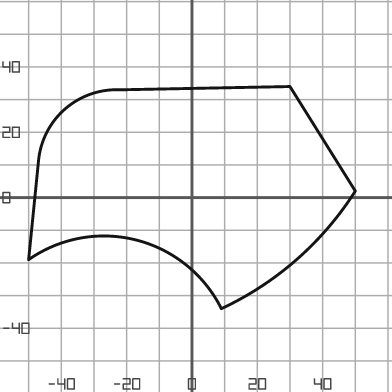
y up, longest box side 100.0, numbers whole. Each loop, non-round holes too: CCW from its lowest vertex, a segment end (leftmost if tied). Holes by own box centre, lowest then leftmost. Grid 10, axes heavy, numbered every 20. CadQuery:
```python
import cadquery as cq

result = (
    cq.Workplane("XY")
    .moveTo(9.0, -34.0)
    .threePointArc((32.0, -19.0), (50.0, 2.0))
    .lineTo(30.0, 34.0)
    .lineTo(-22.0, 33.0)
    .threePointArc((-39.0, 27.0), (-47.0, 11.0))
    .lineTo(-50.0, -19.0)
    .threePointArc((-17.0, -13.0), (9.0, -34.0))
    .close()
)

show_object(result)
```